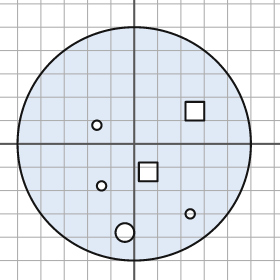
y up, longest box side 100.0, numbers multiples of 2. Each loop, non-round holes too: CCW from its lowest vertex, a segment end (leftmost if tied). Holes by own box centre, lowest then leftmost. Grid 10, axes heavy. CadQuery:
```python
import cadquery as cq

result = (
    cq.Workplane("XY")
    .moveTo(0.0, 0.0)
    .circle(50.0)
    .moveTo(-4.0, -38.0)
    .circle(4.0)
    .moveTo(24.0, -30.0)
    .circle(2.0)
    .moveTo(-14.0, -18.0)
    .circle(2.0)
    .moveTo(2.0, -16.0)
    .lineTo(10.0, -16.0)
    .lineTo(10.0, -8.0)
    .lineTo(2.0, -8.0)
    .close()
    .moveTo(-16.0, 8.0)
    .circle(2.0)
    .moveTo(22.0, 10.0)
    .lineTo(30.0, 10.0)
    .lineTo(30.0, 18.0)
    .lineTo(22.0, 18.0)
    .close()
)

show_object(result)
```